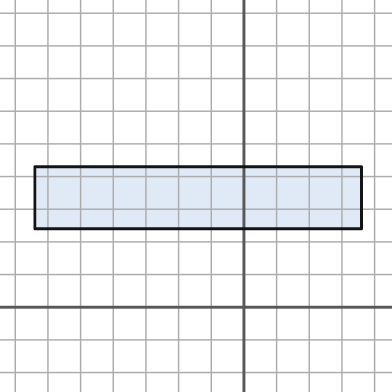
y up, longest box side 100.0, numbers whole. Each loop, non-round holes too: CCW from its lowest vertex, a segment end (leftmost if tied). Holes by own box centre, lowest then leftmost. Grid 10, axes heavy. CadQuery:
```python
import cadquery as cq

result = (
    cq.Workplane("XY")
    .moveTo(-64.0, 24.0)
    .lineTo(36.0, 24.0)
    .lineTo(36.0, 43.0)
    .lineTo(-64.0, 43.0)
    .close()
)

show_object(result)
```